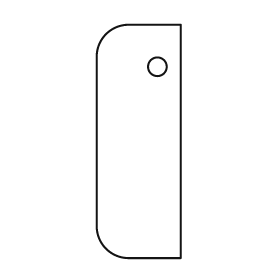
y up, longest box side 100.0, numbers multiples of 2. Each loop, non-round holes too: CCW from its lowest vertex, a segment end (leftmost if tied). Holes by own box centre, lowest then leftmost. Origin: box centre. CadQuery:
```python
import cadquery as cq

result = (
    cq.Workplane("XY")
    .moveTo(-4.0, -50.0)
    .lineTo(18.0, -50.0)
    .lineTo(18.0, 50.0)
    .lineTo(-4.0, 50.0)
    .threePointArc((-14.0, 46.0), (-18.0, 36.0))
    .lineTo(-18.0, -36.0)
    .threePointArc((-14.0, -46.0), (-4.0, -50.0))
    .close()
    .moveTo(8.0, 32.0)
    .circle(4.0)
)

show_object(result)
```